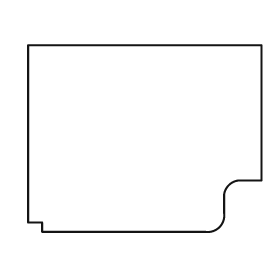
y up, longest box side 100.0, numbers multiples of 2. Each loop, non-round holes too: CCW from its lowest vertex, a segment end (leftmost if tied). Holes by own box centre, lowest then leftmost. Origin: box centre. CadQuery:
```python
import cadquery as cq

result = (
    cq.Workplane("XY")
    .moveTo(-44.0, -40.0)
    .lineTo(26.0, -40.0)
    .threePointArc((32.0, -38.0), (34.0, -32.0))
    .lineTo(34.0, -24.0)
    .threePointArc((36.0, -20.0), (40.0, -18.0))
    .lineTo(50.0, -18.0)
    .lineTo(50.0, 40.0)
    .lineTo(-50.0, 40.0)
    .lineTo(-50.0, -36.0)
    .lineTo(-44.0, -36.0)
    .close()
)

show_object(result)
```